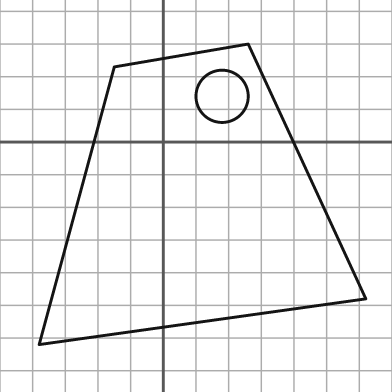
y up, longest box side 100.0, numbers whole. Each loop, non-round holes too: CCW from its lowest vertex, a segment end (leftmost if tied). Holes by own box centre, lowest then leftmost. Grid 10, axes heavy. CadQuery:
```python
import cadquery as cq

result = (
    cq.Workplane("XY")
    .moveTo(-38.0, -62.0)
    .lineTo(62.0, -48.0)
    .lineTo(26.0, 30.0)
    .lineTo(-15.0, 23.0)
    .close()
    .moveTo(18.0, 14.0)
    .circle(8.0)
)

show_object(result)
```